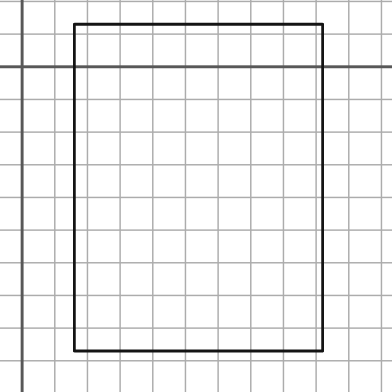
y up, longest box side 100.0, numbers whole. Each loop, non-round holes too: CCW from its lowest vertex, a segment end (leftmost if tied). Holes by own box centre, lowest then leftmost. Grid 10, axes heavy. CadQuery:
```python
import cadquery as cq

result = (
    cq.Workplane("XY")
    .moveTo(16.0, -87.0)
    .lineTo(92.0, -87.0)
    .lineTo(92.0, 13.0)
    .lineTo(16.0, 13.0)
    .close()
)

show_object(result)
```